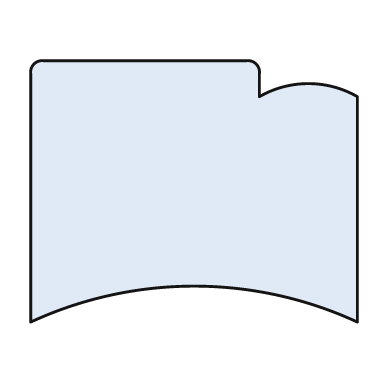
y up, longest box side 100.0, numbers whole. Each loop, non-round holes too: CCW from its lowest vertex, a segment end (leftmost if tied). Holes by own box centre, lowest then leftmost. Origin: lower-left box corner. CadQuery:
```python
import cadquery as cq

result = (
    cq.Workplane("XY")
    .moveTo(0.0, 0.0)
    .threePointArc((50.0, 11.0), (100.0, 0.0))
    .lineTo(100.0, 69.0)
    .threePointArc((85.0, 73.0), (70.0, 69.0))
    .lineTo(70.0, 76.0)
    .threePointArc((69.0, 79.0), (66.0, 80.0))
    .lineTo(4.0, 80.0)
    .threePointArc((1.0, 79.0), (0.0, 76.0))
    .close()
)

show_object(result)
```